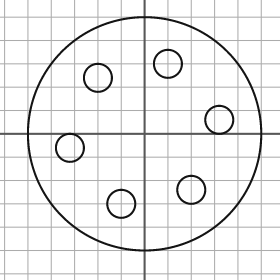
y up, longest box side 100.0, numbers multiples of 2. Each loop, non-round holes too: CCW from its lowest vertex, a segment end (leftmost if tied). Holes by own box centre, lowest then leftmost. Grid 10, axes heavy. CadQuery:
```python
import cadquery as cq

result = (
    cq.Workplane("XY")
    .moveTo(0.0, 0.0)
    .circle(50.0)
    .moveTo(-10.0, -30.0)
    .circle(6.0)
    .moveTo(20.0, -24.0)
    .circle(6.0)
    .moveTo(-32.0, -6.0)
    .circle(6.0)
    .moveTo(32.0, 6.0)
    .circle(6.0)
    .moveTo(-20.0, 24.0)
    .circle(6.0)
    .moveTo(10.0, 30.0)
    .circle(6.0)
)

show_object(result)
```